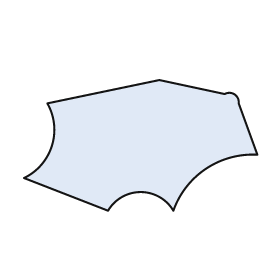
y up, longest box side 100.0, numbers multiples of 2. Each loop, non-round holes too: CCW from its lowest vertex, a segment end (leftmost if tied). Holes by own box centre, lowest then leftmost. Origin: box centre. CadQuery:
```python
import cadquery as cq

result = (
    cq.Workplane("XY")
    .moveTo(-14.0, -28.0)
    .threePointArc((0.0, -20.0), (14.0, -28.0))
    .threePointArc((28.0, -10.0), (50.0, -4.0))
    .lineTo(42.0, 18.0)
    .threePointArc((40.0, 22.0), (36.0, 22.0))
    .lineTo(8.0, 28.0)
    .lineTo(-40.0, 18.0)
    .threePointArc((-38.0, 0.0), (-50.0, -14.0))
    .close()
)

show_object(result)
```